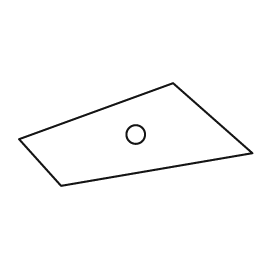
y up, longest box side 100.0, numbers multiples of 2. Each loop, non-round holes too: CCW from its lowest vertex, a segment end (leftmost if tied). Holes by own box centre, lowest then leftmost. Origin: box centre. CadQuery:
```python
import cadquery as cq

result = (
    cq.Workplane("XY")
    .moveTo(-32.0, -22.0)
    .lineTo(50.0, -8.0)
    .lineTo(16.0, 22.0)
    .lineTo(-50.0, -2.0)
    .close()
    .moveTo(0.0, 0.0)
    .circle(4.0)
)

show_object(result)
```